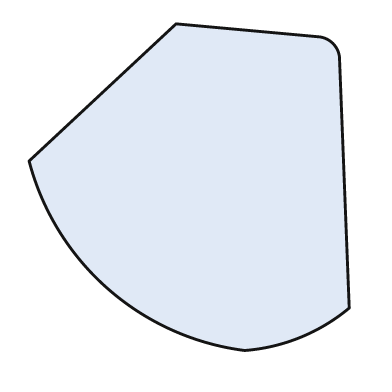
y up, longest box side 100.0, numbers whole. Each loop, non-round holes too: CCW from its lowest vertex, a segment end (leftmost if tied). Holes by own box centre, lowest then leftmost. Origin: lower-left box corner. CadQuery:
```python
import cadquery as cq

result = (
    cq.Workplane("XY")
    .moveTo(66.0, 0.0)
    .threePointArc((83.0, 4.0), (98.0, 13.0))
    .lineTo(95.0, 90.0)
    .threePointArc((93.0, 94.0), (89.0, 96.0))
    .lineTo(45.0, 100.0)
    .lineTo(0.0, 58.0)
    .threePointArc((24.0, 19.0), (66.0, 0.0))
    .close()
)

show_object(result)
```